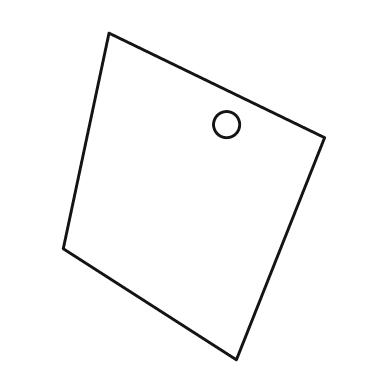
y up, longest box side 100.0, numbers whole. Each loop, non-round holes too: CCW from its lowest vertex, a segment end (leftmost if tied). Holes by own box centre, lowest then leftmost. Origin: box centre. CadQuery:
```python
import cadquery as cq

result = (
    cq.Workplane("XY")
    .moveTo(13.0, -50.0)
    .lineTo(40.0, 18.0)
    .lineTo(-26.0, 50.0)
    .lineTo(-40.0, -16.0)
    .close()
    .moveTo(10.0, 22.0)
    .circle(4.0)
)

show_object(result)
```